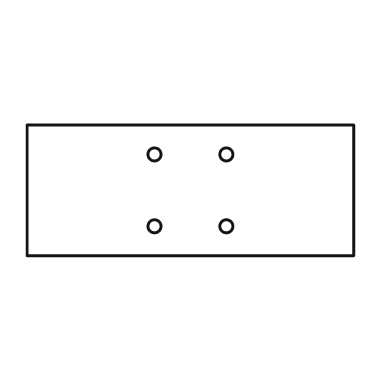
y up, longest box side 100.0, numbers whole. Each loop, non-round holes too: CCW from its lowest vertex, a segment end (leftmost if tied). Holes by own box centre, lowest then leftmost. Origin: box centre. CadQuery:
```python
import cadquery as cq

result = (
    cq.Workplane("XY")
    .moveTo(-50.0, -20.0)
    .lineTo(50.0, -20.0)
    .lineTo(50.0, 20.0)
    .lineTo(-50.0, 20.0)
    .close()
    .moveTo(-11.0, -11.0)
    .circle(2.0)
    .moveTo(11.0, -11.0)
    .circle(2.0)
    .moveTo(-11.0, 11.0)
    .circle(2.0)
    .moveTo(11.0, 11.0)
    .circle(2.0)
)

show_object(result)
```